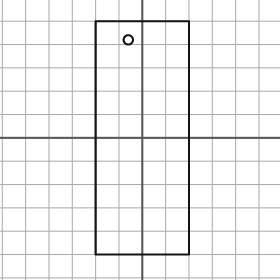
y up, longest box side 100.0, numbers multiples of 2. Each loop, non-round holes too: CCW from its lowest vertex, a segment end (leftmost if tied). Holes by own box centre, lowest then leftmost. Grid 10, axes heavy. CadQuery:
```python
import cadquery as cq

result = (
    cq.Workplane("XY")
    .moveTo(-20.0, -50.0)
    .lineTo(20.0, -50.0)
    .lineTo(20.0, 50.0)
    .lineTo(-20.0, 50.0)
    .close()
    .moveTo(-6.0, 42.0)
    .circle(2.0)
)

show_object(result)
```